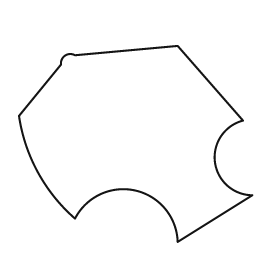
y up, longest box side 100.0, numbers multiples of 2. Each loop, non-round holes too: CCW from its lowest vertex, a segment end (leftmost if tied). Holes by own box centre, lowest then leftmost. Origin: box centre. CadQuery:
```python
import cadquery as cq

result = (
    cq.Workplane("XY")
    .moveTo(18.0, -42.0)
    .lineTo(50.0, -22.0)
    .threePointArc((34.0, -8.0), (46.0, 10.0))
    .lineTo(18.0, 42.0)
    .lineTo(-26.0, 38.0)
    .threePointArc((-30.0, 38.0), (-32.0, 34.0))
    .lineTo(-50.0, 12.0)
    .threePointArc((-42.0, -12.0), (-26.0, -32.0))
    .threePointArc((0.0, -20.0), (18.0, -42.0))
    .close()
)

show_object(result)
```